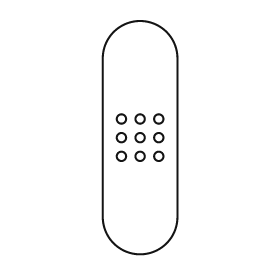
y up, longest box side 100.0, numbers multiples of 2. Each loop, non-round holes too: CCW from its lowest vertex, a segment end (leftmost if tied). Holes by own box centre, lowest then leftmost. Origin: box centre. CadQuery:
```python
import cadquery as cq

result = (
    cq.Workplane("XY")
    .moveTo(-16.0, -34.0)
    .threePointArc((0.0, -50.0), (16.0, -34.0))
    .lineTo(16.0, 34.0)
    .threePointArc((0.0, 50.0), (-16.0, 34.0))
    .close()
    .moveTo(-8.0, -8.0)
    .circle(2.0)
    .moveTo(0.0, -8.0)
    .circle(2.0)
    .moveTo(8.0, -8.0)
    .circle(2.0)
    .moveTo(-8.0, 0.0)
    .circle(2.0)
    .moveTo(0.0, 0.0)
    .circle(2.0)
    .moveTo(8.0, 0.0)
    .circle(2.0)
    .moveTo(-8.0, 8.0)
    .circle(2.0)
    .moveTo(0.0, 8.0)
    .circle(2.0)
    .moveTo(8.0, 8.0)
    .circle(2.0)
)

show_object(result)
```